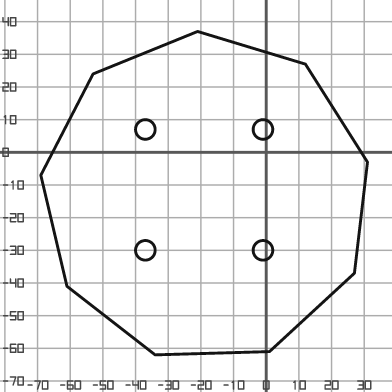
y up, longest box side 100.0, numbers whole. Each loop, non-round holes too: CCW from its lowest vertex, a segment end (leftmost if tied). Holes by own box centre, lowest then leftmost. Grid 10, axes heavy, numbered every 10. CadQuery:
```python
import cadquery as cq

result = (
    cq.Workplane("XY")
    .moveTo(-34.0, -62.0)
    .lineTo(1.0, -61.0)
    .lineTo(27.0, -37.0)
    .lineTo(31.0, -3.0)
    .lineTo(12.0, 27.0)
    .lineTo(-21.0, 37.0)
    .lineTo(-53.0, 24.0)
    .lineTo(-69.0, -7.0)
    .lineTo(-61.0, -41.0)
    .close()
    .moveTo(-37.0, -30.0)
    .circle(3.0)
    .moveTo(-1.0, -30.0)
    .circle(3.0)
    .moveTo(-37.0, 7.0)
    .circle(3.0)
    .moveTo(-1.0, 7.0)
    .circle(3.0)
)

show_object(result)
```